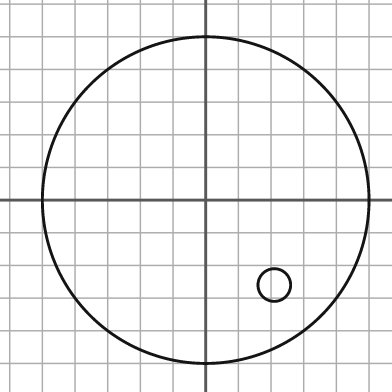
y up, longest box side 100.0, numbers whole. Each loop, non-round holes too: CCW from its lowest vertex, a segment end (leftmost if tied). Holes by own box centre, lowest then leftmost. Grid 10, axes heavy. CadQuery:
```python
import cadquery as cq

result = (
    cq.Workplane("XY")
    .moveTo(0.0, 0.0)
    .circle(50.0)
    .moveTo(21.0, -26.0)
    .circle(5.0)
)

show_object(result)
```